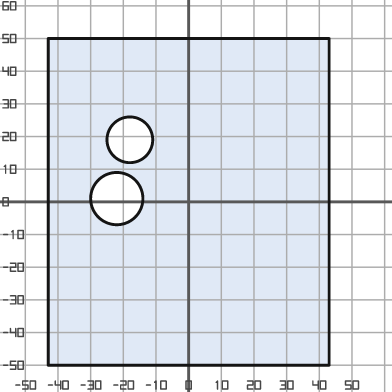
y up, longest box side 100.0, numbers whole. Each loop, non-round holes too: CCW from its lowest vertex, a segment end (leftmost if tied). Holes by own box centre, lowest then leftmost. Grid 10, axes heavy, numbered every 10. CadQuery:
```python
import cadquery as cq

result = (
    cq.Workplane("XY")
    .moveTo(-43.0, -50.0)
    .lineTo(43.0, -50.0)
    .lineTo(43.0, 50.0)
    .lineTo(-43.0, 50.0)
    .close()
    .moveTo(-22.0, 1.0)
    .circle(8.0)
    .moveTo(-18.0, 19.0)
    .circle(7.0)
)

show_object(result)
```